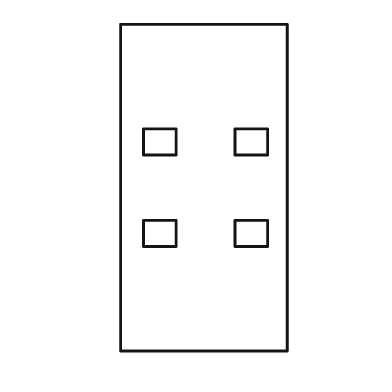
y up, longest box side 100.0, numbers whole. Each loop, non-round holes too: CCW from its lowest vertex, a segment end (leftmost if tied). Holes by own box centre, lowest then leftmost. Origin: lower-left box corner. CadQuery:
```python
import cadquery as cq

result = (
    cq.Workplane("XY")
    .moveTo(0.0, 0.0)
    .lineTo(51.0, 0.0)
    .lineTo(51.0, 100.0)
    .lineTo(0.0, 100.0)
    .close()
    .moveTo(7.0, 32.0)
    .lineTo(17.0, 32.0)
    .lineTo(17.0, 40.0)
    .lineTo(7.0, 40.0)
    .close()
    .moveTo(35.0, 32.0)
    .lineTo(45.0, 32.0)
    .lineTo(45.0, 40.0)
    .lineTo(35.0, 40.0)
    .close()
    .moveTo(7.0, 60.0)
    .lineTo(17.0, 60.0)
    .lineTo(17.0, 68.0)
    .lineTo(7.0, 68.0)
    .close()
    .moveTo(35.0, 60.0)
    .lineTo(45.0, 60.0)
    .lineTo(45.0, 68.0)
    .lineTo(35.0, 68.0)
    .close()
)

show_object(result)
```